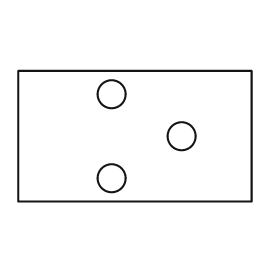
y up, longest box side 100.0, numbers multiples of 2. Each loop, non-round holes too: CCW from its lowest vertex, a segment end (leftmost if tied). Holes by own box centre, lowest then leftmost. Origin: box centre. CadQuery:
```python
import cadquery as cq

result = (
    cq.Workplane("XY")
    .moveTo(-50.0, -28.0)
    .lineTo(50.0, -28.0)
    .lineTo(50.0, 28.0)
    .lineTo(-50.0, 28.0)
    .close()
    .moveTo(-10.0, -18.0)
    .circle(6.0)
    .moveTo(20.0, 0.0)
    .circle(6.0)
    .moveTo(-10.0, 18.0)
    .circle(6.0)
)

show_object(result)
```